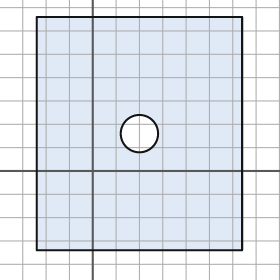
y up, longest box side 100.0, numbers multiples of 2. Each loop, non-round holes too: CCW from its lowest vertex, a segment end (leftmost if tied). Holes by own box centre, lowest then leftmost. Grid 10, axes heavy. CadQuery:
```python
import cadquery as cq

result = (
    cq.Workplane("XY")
    .moveTo(-24.0, -34.0)
    .lineTo(64.0, -34.0)
    .lineTo(64.0, 66.0)
    .lineTo(-24.0, 66.0)
    .close()
    .moveTo(20.0, 16.0)
    .circle(8.0)
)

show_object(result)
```